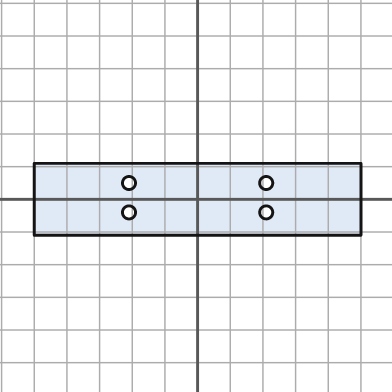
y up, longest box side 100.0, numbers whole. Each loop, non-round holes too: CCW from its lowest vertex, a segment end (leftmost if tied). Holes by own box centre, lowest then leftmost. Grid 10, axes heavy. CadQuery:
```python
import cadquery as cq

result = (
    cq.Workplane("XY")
    .moveTo(-50.0, -11.0)
    .lineTo(50.0, -11.0)
    .lineTo(50.0, 11.0)
    .lineTo(-50.0, 11.0)
    .close()
    .moveTo(-21.0, -4.0)
    .circle(2.0)
    .moveTo(21.0, -4.0)
    .circle(2.0)
    .moveTo(-21.0, 5.0)
    .circle(2.0)
    .moveTo(21.0, 5.0)
    .circle(2.0)
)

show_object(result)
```